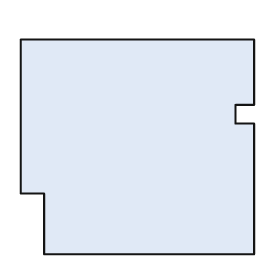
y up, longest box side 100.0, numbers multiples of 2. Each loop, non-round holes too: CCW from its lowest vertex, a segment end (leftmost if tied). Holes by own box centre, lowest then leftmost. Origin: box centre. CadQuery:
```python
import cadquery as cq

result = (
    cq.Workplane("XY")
    .moveTo(-40.0, -46.0)
    .lineTo(50.0, -46.0)
    .lineTo(50.0, 10.0)
    .lineTo(42.0, 10.0)
    .lineTo(42.0, 18.0)
    .lineTo(50.0, 18.0)
    .lineTo(50.0, 46.0)
    .lineTo(-50.0, 46.0)
    .lineTo(-50.0, -20.0)
    .lineTo(-40.0, -20.0)
    .close()
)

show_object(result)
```